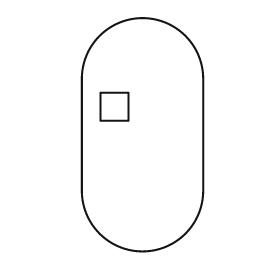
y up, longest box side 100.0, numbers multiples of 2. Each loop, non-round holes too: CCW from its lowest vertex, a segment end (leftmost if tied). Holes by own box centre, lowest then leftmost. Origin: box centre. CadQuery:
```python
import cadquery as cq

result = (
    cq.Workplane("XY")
    .moveTo(-26.0, -24.0)
    .threePointArc((0.0, -50.0), (26.0, -24.0))
    .lineTo(26.0, 24.0)
    .threePointArc((0.0, 50.0), (-26.0, 24.0))
    .close()
    .moveTo(-18.0, 6.0)
    .lineTo(-6.0, 6.0)
    .lineTo(-6.0, 18.0)
    .lineTo(-18.0, 18.0)
    .close()
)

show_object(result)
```